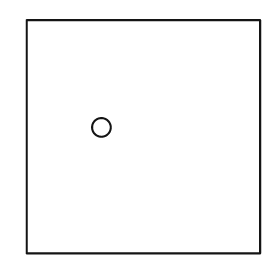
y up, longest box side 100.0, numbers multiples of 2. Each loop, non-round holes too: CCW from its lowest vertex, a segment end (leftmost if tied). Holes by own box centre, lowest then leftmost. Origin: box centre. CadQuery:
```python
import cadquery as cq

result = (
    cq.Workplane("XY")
    .moveTo(-50.0, -50.0)
    .lineTo(50.0, -50.0)
    .lineTo(50.0, 50.0)
    .lineTo(-50.0, 50.0)
    .close()
    .moveTo(-18.0, 4.0)
    .circle(4.0)
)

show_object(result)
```